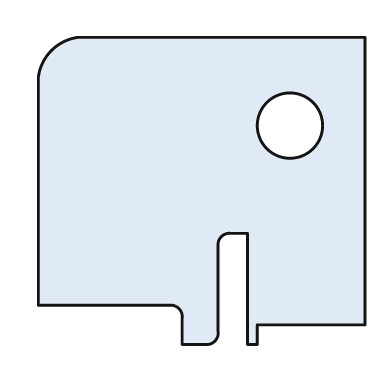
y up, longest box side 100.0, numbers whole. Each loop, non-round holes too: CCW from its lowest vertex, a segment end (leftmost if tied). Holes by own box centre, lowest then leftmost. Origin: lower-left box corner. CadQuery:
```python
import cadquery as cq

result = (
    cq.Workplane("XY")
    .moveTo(44.0, 0.0)
    .lineTo(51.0, 0.0)
    .threePointArc((54.0, 1.0), (55.0, 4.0))
    .lineTo(55.0, 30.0)
    .threePointArc((56.0, 33.0), (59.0, 34.0))
    .lineTo(64.0, 34.0)
    .lineTo(64.0, 0.0)
    .lineTo(67.0, 0.0)
    .lineTo(67.0, 6.0)
    .lineTo(100.0, 6.0)
    .lineTo(100.0, 94.0)
    .lineTo(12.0, 94.0)
    .threePointArc((4.0, 90.0), (0.0, 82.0))
    .lineTo(0.0, 12.0)
    .lineTo(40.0, 12.0)
    .threePointArc((43.0, 11.0), (44.0, 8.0))
    .close()
    .moveTo(77.0, 67.0)
    .circle(10.0)
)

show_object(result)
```